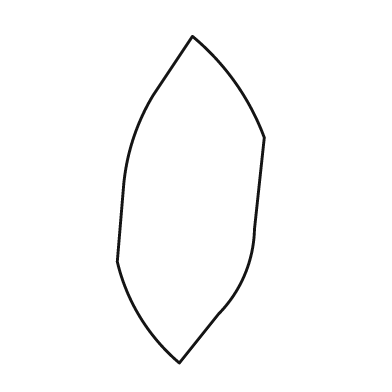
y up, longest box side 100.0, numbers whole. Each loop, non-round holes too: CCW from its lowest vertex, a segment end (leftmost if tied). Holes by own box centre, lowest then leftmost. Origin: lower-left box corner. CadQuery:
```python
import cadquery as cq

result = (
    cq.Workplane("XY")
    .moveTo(19.0, 0.0)
    .lineTo(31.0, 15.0)
    .threePointArc((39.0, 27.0), (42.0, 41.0))
    .lineTo(45.0, 69.0)
    .threePointArc((36.0, 86.0), (23.0, 100.0))
    .lineTo(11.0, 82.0)
    .threePointArc((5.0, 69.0), (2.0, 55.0))
    .lineTo(0.0, 31.0)
    .threePointArc((7.0, 14.0), (19.0, 0.0))
    .close()
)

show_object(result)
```